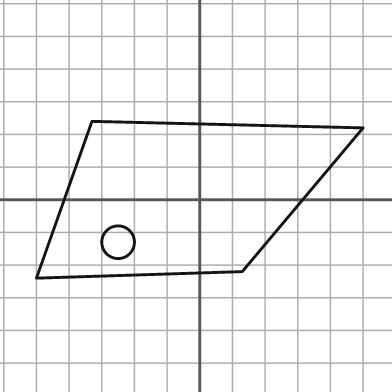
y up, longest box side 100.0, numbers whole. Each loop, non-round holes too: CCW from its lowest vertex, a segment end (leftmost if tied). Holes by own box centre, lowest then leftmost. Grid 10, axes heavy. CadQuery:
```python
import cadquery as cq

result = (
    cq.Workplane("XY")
    .moveTo(-50.0, -24.0)
    .lineTo(13.0, -22.0)
    .lineTo(50.0, 22.0)
    .lineTo(-33.0, 24.0)
    .close()
    .moveTo(-25.0, -13.0)
    .circle(5.0)
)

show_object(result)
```